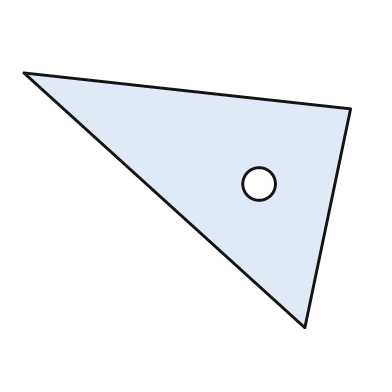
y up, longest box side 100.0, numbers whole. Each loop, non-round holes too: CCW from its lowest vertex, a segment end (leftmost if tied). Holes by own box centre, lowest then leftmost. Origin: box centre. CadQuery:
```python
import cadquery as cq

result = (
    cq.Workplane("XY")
    .moveTo(36.0, -39.0)
    .lineTo(50.0, 28.0)
    .lineTo(-50.0, 39.0)
    .close()
    .moveTo(22.0, 5.0)
    .circle(5.0)
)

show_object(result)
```